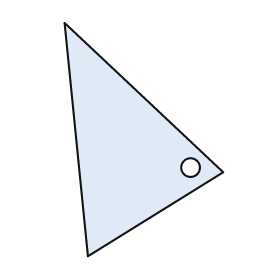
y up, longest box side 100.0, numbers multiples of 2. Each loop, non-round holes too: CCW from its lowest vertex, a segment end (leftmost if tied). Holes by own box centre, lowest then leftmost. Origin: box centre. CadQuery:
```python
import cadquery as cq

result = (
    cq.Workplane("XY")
    .moveTo(-24.0, -50.0)
    .lineTo(34.0, -14.0)
    .lineTo(-34.0, 50.0)
    .close()
    .moveTo(20.0, -12.0)
    .circle(4.0)
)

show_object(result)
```